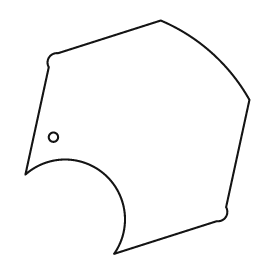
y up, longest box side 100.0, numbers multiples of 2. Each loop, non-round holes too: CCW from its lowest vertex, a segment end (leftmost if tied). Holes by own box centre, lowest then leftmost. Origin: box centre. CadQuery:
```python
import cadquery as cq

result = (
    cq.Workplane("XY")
    .moveTo(-10.0, -50.0)
    .lineTo(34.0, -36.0)
    .threePointArc((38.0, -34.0), (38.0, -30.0))
    .lineTo(48.0, 16.0)
    .threePointArc((32.0, 36.0), (10.0, 50.0))
    .lineTo(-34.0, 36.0)
    .threePointArc((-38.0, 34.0), (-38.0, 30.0))
    .lineTo(-48.0, -16.0)
    .threePointArc((-14.0, -16.0), (-10.0, -50.0))
    .close()
    .moveTo(-36.0, 0.0)
    .circle(2.0)
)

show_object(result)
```